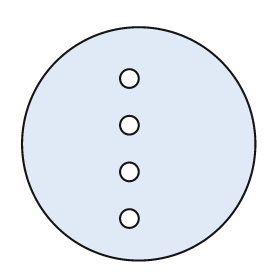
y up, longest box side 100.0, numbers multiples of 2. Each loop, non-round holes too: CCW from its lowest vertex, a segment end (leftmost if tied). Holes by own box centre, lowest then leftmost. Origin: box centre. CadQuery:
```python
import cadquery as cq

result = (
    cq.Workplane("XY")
    .moveTo(0.0, 0.0)
    .circle(50.0)
    .moveTo(-4.0, -32.0)
    .circle(4.0)
    .moveTo(-4.0, -12.0)
    .circle(4.0)
    .moveTo(-4.0, 8.0)
    .circle(4.0)
    .moveTo(-4.0, 28.0)
    .circle(4.0)
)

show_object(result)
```